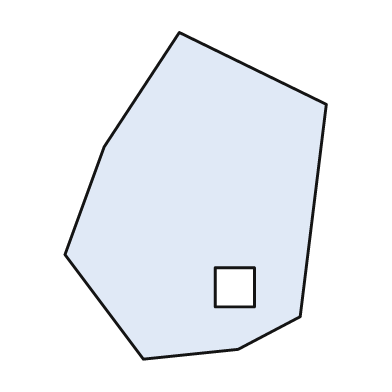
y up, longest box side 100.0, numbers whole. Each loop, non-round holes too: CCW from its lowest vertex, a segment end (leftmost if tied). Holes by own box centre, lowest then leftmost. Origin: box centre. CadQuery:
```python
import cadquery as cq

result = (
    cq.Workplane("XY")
    .moveTo(-16.0, -50.0)
    .lineTo(13.0, -47.0)
    .lineTo(32.0, -37.0)
    .lineTo(40.0, 28.0)
    .lineTo(-5.0, 50.0)
    .lineTo(-28.0, 15.0)
    .lineTo(-40.0, -18.0)
    .close()
    .moveTo(6.0, -34.0)
    .lineTo(18.0, -34.0)
    .lineTo(18.0, -22.0)
    .lineTo(6.0, -22.0)
    .close()
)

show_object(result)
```